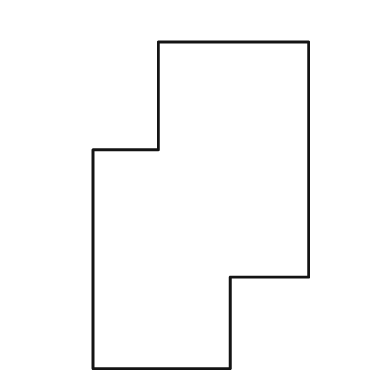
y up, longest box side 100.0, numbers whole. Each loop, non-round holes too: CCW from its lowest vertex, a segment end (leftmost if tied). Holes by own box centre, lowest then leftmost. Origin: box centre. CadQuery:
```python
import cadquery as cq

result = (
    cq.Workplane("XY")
    .moveTo(-33.0, -50.0)
    .lineTo(9.0, -50.0)
    .lineTo(9.0, -22.0)
    .lineTo(33.0, -22.0)
    .lineTo(33.0, 50.0)
    .lineTo(-13.0, 50.0)
    .lineTo(-13.0, 17.0)
    .lineTo(-33.0, 17.0)
    .close()
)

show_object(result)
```